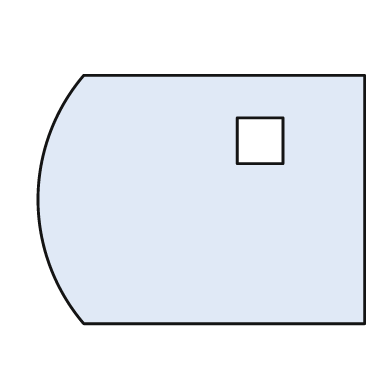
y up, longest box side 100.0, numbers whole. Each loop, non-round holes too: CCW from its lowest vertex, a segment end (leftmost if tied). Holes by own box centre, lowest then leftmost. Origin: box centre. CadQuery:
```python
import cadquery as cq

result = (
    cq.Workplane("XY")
    .moveTo(-36.0, -38.0)
    .lineTo(50.0, -38.0)
    .lineTo(50.0, 38.0)
    .lineTo(-36.0, 38.0)
    .threePointArc((-50.0, 0.0), (-36.0, -38.0))
    .close()
    .moveTo(11.0, 11.0)
    .lineTo(25.0, 11.0)
    .lineTo(25.0, 25.0)
    .lineTo(11.0, 25.0)
    .close()
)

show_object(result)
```